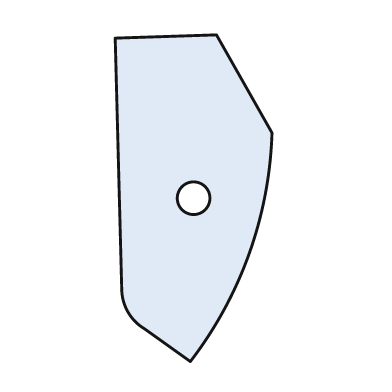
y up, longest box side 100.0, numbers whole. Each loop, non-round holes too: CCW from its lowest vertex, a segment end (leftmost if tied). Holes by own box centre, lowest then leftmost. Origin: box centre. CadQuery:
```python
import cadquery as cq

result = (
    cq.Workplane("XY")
    .moveTo(-1.0, -50.0)
    .threePointArc((17.0, -17.0), (24.0, 20.0))
    .lineTo(7.0, 50.0)
    .lineTo(-24.0, 49.0)
    .lineTo(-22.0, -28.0)
    .threePointArc((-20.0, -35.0), (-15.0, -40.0))
    .close()
    .moveTo(0.0, 0.0)
    .circle(5.0)
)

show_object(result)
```